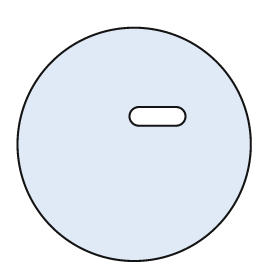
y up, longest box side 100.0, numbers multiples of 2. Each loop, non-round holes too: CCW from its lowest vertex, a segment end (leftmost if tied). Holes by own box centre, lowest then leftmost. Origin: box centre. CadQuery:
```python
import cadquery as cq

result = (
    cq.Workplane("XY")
    .moveTo(0.0, 0.0)
    .circle(50.0)
    .moveTo(2.0, 8.0)
    .lineTo(18.0, 8.0)
    .threePointArc((22.0, 12.0), (18.0, 16.0))
    .lineTo(2.0, 16.0)
    .threePointArc((-2.0, 12.0), (2.0, 8.0))
    .close()
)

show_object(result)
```